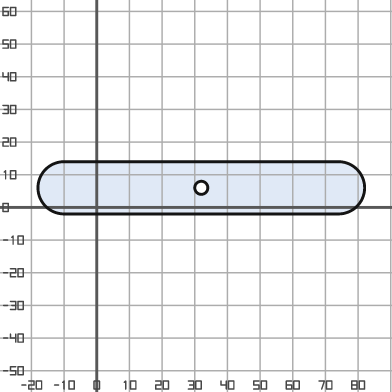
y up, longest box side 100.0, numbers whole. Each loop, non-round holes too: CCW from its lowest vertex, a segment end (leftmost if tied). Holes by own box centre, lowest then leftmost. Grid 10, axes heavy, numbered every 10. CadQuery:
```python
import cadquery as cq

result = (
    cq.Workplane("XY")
    .moveTo(-10.0, -2.0)
    .lineTo(74.0, -2.0)
    .threePointArc((82.0, 6.0), (74.0, 14.0))
    .lineTo(-10.0, 14.0)
    .threePointArc((-18.0, 6.0), (-10.0, -2.0))
    .close()
    .moveTo(32.0, 6.0)
    .circle(2.0)
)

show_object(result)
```